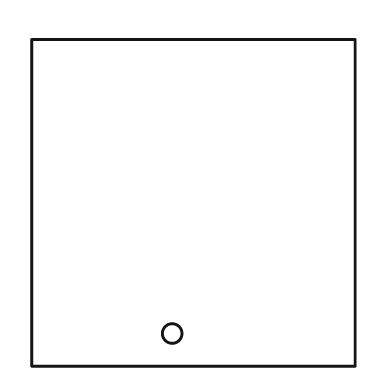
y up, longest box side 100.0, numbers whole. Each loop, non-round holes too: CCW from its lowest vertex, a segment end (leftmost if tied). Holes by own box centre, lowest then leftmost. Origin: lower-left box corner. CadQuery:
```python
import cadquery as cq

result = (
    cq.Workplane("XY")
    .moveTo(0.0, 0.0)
    .lineTo(99.0, 0.0)
    .lineTo(99.0, 100.0)
    .lineTo(0.0, 100.0)
    .close()
    .moveTo(43.0, 10.0)
    .circle(3.0)
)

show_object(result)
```